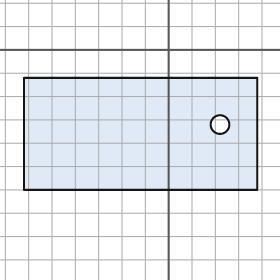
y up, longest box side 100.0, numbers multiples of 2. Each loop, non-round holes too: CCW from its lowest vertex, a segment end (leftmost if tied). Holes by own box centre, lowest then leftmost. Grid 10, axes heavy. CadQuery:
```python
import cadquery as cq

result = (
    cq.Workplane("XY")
    .moveTo(-62.0, -60.0)
    .lineTo(38.0, -60.0)
    .lineTo(38.0, -12.0)
    .lineTo(-62.0, -12.0)
    .close()
    .moveTo(22.0, -32.0)
    .circle(4.0)
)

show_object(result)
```